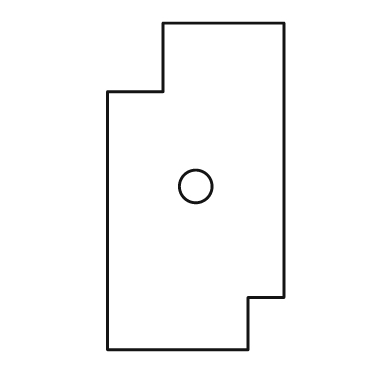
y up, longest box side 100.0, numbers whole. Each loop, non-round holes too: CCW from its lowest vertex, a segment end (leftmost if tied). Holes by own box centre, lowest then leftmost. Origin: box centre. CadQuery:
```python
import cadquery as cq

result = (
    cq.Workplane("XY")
    .moveTo(-27.0, -50.0)
    .lineTo(16.0, -50.0)
    .lineTo(16.0, -34.0)
    .lineTo(27.0, -34.0)
    .lineTo(27.0, 50.0)
    .lineTo(-10.0, 50.0)
    .lineTo(-10.0, 29.0)
    .lineTo(-27.0, 29.0)
    .close()
    .moveTo(0.0, 0.0)
    .circle(5.0)
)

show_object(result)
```